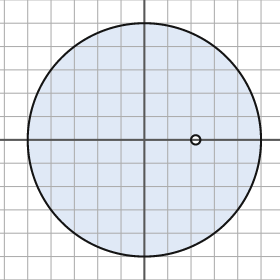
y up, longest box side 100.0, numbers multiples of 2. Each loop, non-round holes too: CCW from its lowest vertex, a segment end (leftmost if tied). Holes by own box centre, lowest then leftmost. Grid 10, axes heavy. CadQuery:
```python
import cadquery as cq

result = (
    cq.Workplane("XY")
    .moveTo(0.0, 0.0)
    .circle(50.0)
    .moveTo(22.0, 0.0)
    .circle(2.0)
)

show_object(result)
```